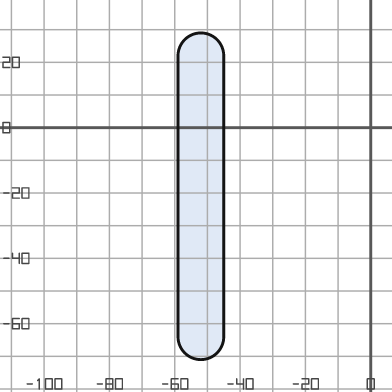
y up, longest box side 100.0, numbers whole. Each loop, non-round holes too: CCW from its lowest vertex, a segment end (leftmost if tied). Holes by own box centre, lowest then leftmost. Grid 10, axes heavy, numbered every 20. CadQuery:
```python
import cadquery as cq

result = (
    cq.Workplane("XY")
    .moveTo(-59.0, -64.0)
    .threePointArc((-52.0, -71.0), (-45.0, -64.0))
    .lineTo(-45.0, 22.0)
    .threePointArc((-52.0, 29.0), (-59.0, 22.0))
    .close()
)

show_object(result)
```